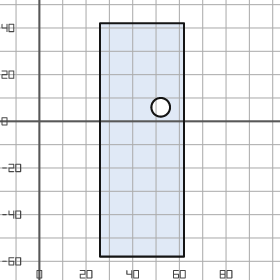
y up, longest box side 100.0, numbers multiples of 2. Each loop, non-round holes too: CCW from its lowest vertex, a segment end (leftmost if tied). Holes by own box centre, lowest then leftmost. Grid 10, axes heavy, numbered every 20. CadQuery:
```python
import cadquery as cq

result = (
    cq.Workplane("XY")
    .moveTo(26.0, -58.0)
    .lineTo(62.0, -58.0)
    .lineTo(62.0, 42.0)
    .lineTo(26.0, 42.0)
    .close()
    .moveTo(52.0, 6.0)
    .circle(4.0)
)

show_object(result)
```